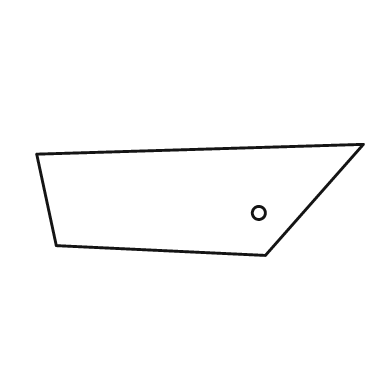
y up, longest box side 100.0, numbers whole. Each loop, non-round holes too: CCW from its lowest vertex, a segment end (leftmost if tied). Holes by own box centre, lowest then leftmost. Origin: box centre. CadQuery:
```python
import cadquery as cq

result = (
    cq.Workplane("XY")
    .moveTo(20.0, -17.0)
    .lineTo(50.0, 17.0)
    .lineTo(-50.0, 14.0)
    .lineTo(-44.0, -14.0)
    .close()
    .moveTo(18.0, -4.0)
    .circle(2.0)
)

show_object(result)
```